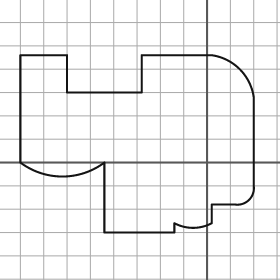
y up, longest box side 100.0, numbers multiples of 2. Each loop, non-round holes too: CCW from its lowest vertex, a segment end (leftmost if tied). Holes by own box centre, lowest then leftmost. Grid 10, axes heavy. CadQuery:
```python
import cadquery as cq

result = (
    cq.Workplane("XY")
    .moveTo(-44.0, -30.0)
    .lineTo(-14.0, -30.0)
    .lineTo(-14.0, -26.0)
    .threePointArc((-6.0, -28.0), (2.0, -26.0))
    .lineTo(2.0, -18.0)
    .lineTo(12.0, -18.0)
    .threePointArc((18.0, -16.0), (20.0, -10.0))
    .lineTo(20.0, 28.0)
    .threePointArc((14.0, 40.0), (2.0, 46.0))
    .lineTo(-28.0, 46.0)
    .lineTo(-28.0, 30.0)
    .lineTo(-60.0, 30.0)
    .lineTo(-60.0, 46.0)
    .lineTo(-80.0, 46.0)
    .lineTo(-80.0, 0.0)
    .threePointArc((-62.0, -6.0), (-44.0, 0.0))
    .close()
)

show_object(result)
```